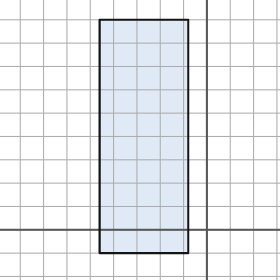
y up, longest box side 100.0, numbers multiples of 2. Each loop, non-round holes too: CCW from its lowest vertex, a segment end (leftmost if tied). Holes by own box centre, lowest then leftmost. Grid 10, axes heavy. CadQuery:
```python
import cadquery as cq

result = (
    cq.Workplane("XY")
    .moveTo(-46.0, -10.0)
    .lineTo(-8.0, -10.0)
    .lineTo(-8.0, 90.0)
    .lineTo(-46.0, 90.0)
    .close()
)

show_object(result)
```